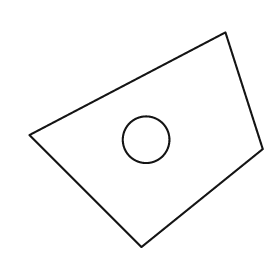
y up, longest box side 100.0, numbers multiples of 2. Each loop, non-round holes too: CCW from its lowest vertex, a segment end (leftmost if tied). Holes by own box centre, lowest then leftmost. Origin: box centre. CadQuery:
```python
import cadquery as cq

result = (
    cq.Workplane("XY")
    .moveTo(-2.0, -46.0)
    .lineTo(50.0, -4.0)
    .lineTo(34.0, 46.0)
    .lineTo(-50.0, 2.0)
    .close()
    .moveTo(0.0, 0.0)
    .circle(10.0)
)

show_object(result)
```